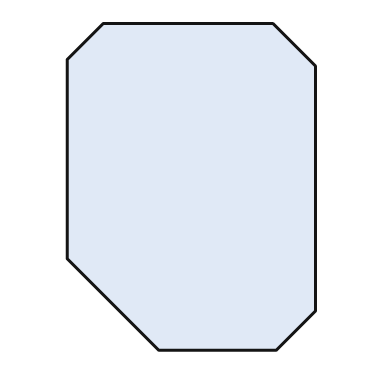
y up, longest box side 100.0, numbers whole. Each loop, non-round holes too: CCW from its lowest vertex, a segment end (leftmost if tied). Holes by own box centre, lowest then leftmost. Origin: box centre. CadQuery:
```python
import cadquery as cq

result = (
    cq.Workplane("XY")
    .moveTo(-10.0, -50.0)
    .lineTo(26.0, -50.0)
    .lineTo(38.0, -38.0)
    .lineTo(38.0, 37.0)
    .lineTo(25.0, 50.0)
    .lineTo(-27.0, 50.0)
    .lineTo(-38.0, 39.0)
    .lineTo(-38.0, -22.0)
    .close()
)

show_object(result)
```